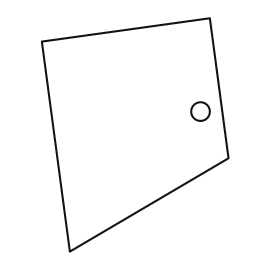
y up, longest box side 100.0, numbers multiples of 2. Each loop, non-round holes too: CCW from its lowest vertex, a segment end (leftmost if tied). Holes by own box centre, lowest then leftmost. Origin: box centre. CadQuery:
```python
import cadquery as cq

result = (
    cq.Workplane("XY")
    .moveTo(-28.0, -50.0)
    .lineTo(40.0, -10.0)
    .lineTo(32.0, 50.0)
    .lineTo(-40.0, 40.0)
    .close()
    .moveTo(28.0, 10.0)
    .circle(4.0)
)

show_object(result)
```